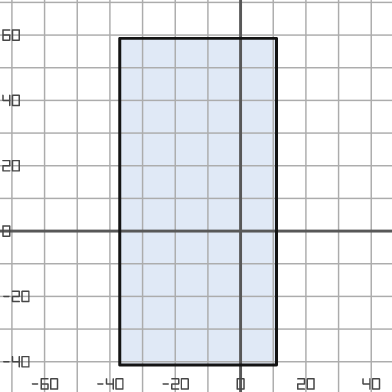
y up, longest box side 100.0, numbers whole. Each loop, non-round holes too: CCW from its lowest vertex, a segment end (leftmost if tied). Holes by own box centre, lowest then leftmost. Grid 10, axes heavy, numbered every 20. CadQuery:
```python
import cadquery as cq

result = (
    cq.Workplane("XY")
    .moveTo(-37.0, -41.0)
    .lineTo(11.0, -41.0)
    .lineTo(11.0, 59.0)
    .lineTo(-37.0, 59.0)
    .close()
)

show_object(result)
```